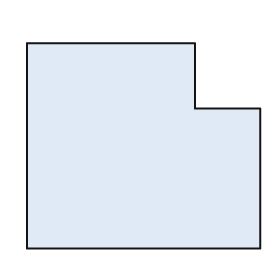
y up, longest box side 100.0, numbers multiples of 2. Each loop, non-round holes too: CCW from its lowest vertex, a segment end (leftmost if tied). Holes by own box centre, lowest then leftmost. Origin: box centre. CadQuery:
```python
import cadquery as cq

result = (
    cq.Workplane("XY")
    .moveTo(-50.0, -44.0)
    .lineTo(50.0, -44.0)
    .lineTo(50.0, 16.0)
    .lineTo(22.0, 16.0)
    .lineTo(22.0, 44.0)
    .lineTo(-50.0, 44.0)
    .close()
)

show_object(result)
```